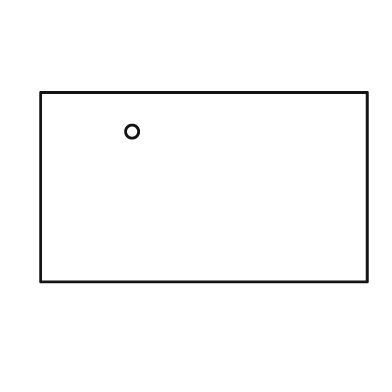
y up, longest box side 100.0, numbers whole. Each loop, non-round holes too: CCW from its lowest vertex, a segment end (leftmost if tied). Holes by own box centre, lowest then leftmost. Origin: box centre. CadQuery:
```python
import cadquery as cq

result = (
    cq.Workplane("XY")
    .moveTo(-50.0, -29.0)
    .lineTo(50.0, -29.0)
    .lineTo(50.0, 29.0)
    .lineTo(-50.0, 29.0)
    .close()
    .moveTo(-22.0, 17.0)
    .circle(2.0)
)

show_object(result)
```